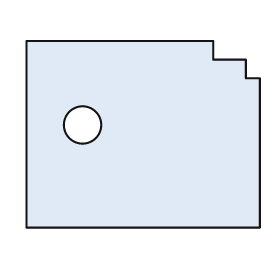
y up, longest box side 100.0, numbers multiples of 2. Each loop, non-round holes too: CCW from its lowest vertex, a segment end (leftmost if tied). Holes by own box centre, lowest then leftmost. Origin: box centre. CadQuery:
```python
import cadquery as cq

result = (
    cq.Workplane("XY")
    .moveTo(-50.0, -40.0)
    .lineTo(50.0, -40.0)
    .lineTo(50.0, 24.0)
    .lineTo(44.0, 24.0)
    .lineTo(44.0, 32.0)
    .lineTo(30.0, 32.0)
    .lineTo(30.0, 40.0)
    .lineTo(-50.0, 40.0)
    .close()
    .moveTo(-26.0, 4.0)
    .circle(8.0)
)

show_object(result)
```